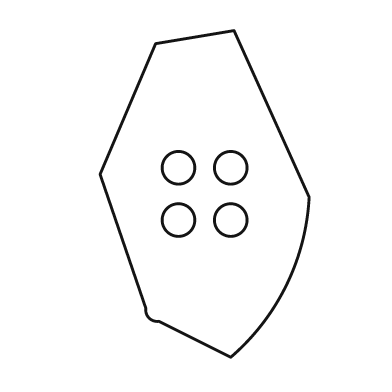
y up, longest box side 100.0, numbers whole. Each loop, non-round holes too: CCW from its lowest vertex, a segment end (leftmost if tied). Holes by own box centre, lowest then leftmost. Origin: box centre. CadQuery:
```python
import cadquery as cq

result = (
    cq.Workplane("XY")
    .moveTo(8.0, -50.0)
    .threePointArc((25.0, -28.0), (32.0, -1.0))
    .lineTo(9.0, 50.0)
    .lineTo(-15.0, 46.0)
    .lineTo(-32.0, 6.0)
    .lineTo(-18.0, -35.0)
    .threePointArc((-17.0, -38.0), (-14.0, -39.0))
    .close()
    .moveTo(-8.0, -8.0)
    .circle(5.0)
    .moveTo(8.0, -8.0)
    .circle(5.0)
    .moveTo(-8.0, 8.0)
    .circle(5.0)
    .moveTo(8.0, 8.0)
    .circle(5.0)
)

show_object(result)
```